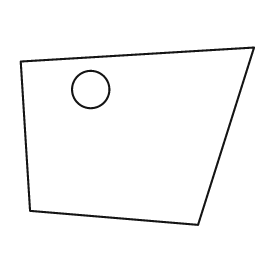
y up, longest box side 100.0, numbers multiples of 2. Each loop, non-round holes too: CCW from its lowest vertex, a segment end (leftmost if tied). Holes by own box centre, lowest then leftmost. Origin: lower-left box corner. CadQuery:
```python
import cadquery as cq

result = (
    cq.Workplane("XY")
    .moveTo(76.0, 0.0)
    .lineTo(100.0, 76.0)
    .lineTo(0.0, 70.0)
    .lineTo(4.0, 6.0)
    .close()
    .moveTo(30.0, 58.0)
    .circle(8.0)
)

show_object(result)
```